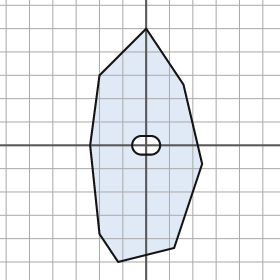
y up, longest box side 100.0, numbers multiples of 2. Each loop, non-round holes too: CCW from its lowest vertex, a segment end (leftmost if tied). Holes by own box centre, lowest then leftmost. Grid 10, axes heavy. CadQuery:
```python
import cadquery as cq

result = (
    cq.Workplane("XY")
    .moveTo(-12.0, -50.0)
    .lineTo(12.0, -44.0)
    .lineTo(24.0, -8.0)
    .lineTo(16.0, 26.0)
    .lineTo(0.0, 50.0)
    .lineTo(-20.0, 30.0)
    .lineTo(-24.0, 0.0)
    .lineTo(-20.0, -38.0)
    .close()
    .moveTo(-2.0, -4.0)
    .lineTo(2.0, -4.0)
    .threePointArc((6.0, 0.0), (2.0, 4.0))
    .lineTo(-2.0, 4.0)
    .threePointArc((-6.0, 0.0), (-2.0, -4.0))
    .close()
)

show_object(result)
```